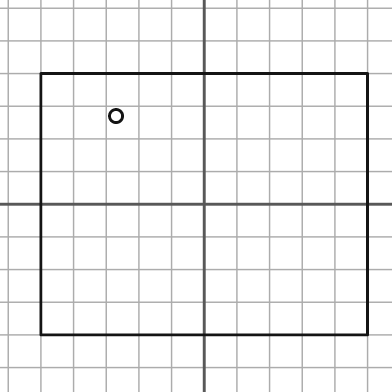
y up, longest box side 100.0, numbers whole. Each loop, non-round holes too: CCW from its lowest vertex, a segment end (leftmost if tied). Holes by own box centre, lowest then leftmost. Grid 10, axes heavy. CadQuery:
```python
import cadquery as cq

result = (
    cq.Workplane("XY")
    .moveTo(-50.0, -40.0)
    .lineTo(50.0, -40.0)
    .lineTo(50.0, 40.0)
    .lineTo(-50.0, 40.0)
    .close()
    .moveTo(-27.0, 27.0)
    .circle(2.0)
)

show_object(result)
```